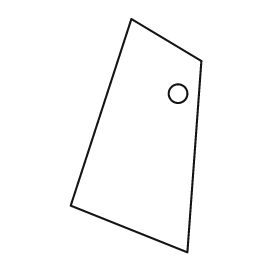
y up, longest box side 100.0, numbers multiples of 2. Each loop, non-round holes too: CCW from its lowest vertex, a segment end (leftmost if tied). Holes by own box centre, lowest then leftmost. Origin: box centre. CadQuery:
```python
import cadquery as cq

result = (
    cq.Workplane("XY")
    .moveTo(22.0, -50.0)
    .lineTo(28.0, 32.0)
    .lineTo(-2.0, 50.0)
    .lineTo(-28.0, -30.0)
    .close()
    .moveTo(18.0, 18.0)
    .circle(4.0)
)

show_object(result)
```